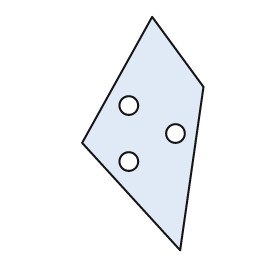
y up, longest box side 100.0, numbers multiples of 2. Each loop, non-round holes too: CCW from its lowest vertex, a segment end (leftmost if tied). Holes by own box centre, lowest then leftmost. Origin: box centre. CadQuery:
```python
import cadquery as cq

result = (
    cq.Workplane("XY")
    .moveTo(16.0, -50.0)
    .lineTo(26.0, 20.0)
    .lineTo(4.0, 50.0)
    .lineTo(-26.0, -4.0)
    .close()
    .moveTo(-6.0, -12.0)
    .circle(4.0)
    .moveTo(14.0, 0.0)
    .circle(4.0)
    .moveTo(-6.0, 12.0)
    .circle(4.0)
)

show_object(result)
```